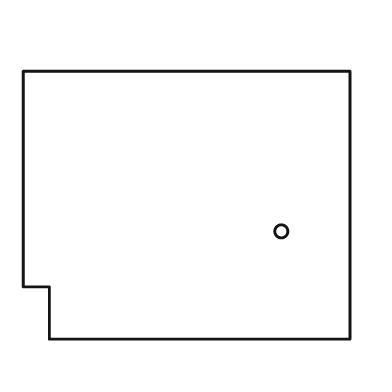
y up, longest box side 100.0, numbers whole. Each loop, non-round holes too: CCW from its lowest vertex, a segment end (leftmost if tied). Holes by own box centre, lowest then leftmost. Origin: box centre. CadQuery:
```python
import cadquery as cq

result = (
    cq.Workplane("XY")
    .moveTo(-42.0, -41.0)
    .lineTo(50.0, -41.0)
    .lineTo(50.0, 41.0)
    .lineTo(-50.0, 41.0)
    .lineTo(-50.0, -25.0)
    .lineTo(-42.0, -25.0)
    .close()
    .moveTo(29.0, -8.0)
    .circle(2.0)
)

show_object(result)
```